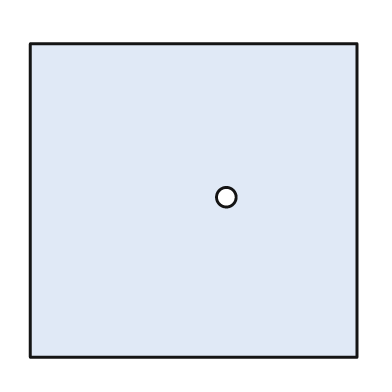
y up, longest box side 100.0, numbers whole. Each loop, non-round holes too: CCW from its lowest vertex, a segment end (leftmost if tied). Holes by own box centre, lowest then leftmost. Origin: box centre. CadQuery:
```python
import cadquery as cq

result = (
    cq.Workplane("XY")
    .moveTo(-50.0, -48.0)
    .lineTo(50.0, -48.0)
    .lineTo(50.0, 48.0)
    .lineTo(-50.0, 48.0)
    .close()
    .moveTo(10.0, 1.0)
    .circle(3.0)
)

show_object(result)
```